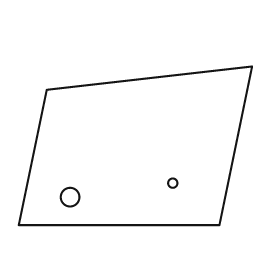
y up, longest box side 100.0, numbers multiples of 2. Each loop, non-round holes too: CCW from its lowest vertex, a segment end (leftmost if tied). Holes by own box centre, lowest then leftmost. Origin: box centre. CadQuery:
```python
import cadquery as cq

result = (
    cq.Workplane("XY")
    .moveTo(-50.0, -34.0)
    .lineTo(36.0, -34.0)
    .lineTo(50.0, 34.0)
    .lineTo(-38.0, 24.0)
    .close()
    .moveTo(-28.0, -22.0)
    .circle(4.0)
    .moveTo(16.0, -16.0)
    .circle(2.0)
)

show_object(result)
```